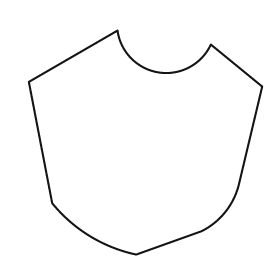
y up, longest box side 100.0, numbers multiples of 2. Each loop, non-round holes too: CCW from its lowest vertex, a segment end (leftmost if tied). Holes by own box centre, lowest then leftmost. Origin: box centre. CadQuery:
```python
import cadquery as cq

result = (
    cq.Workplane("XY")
    .moveTo(-4.0, -48.0)
    .lineTo(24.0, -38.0)
    .threePointArc((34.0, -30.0), (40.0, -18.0))
    .lineTo(50.0, 24.0)
    .lineTo(28.0, 42.0)
    .threePointArc((6.0, 30.0), (-12.0, 48.0))
    .lineTo(-50.0, 26.0)
    .lineTo(-40.0, -26.0)
    .threePointArc((-24.0, -40.0), (-4.0, -48.0))
    .close()
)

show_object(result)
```